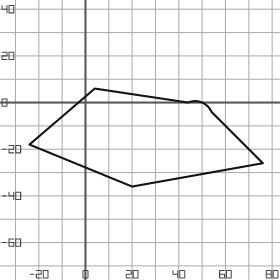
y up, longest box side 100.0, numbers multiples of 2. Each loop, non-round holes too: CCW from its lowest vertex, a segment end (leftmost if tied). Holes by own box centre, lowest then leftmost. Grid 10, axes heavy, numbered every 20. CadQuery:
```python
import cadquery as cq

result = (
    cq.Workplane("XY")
    .moveTo(20.0, -36.0)
    .lineTo(76.0, -26.0)
    .lineTo(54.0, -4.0)
    .threePointArc((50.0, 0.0), (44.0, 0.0))
    .lineTo(4.0, 6.0)
    .lineTo(-24.0, -18.0)
    .close()
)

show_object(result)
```